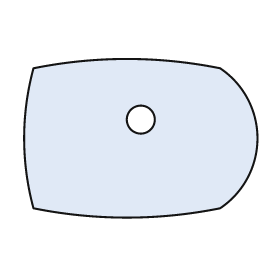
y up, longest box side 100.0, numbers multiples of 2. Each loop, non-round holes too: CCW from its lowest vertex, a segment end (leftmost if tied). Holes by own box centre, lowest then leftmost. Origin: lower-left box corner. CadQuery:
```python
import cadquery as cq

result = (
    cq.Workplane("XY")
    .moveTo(4.0, 4.0)
    .threePointArc((44.0, 0.0), (84.0, 4.0))
    .threePointArc((100.0, 34.0), (84.0, 64.0))
    .threePointArc((44.0, 68.0), (4.0, 64.0))
    .threePointArc((0.0, 34.0), (4.0, 4.0))
    .close()
    .moveTo(50.0, 42.0)
    .circle(6.0)
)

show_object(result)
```